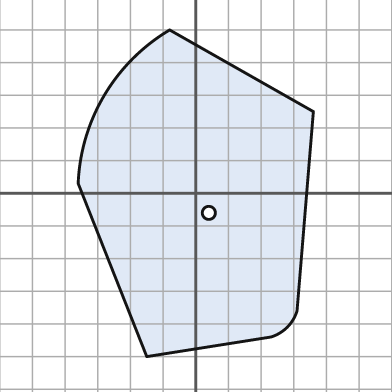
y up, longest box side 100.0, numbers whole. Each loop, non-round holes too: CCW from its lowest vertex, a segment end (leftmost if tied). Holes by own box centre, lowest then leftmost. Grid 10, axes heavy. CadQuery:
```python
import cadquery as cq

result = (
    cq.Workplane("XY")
    .moveTo(-15.0, -50.0)
    .lineTo(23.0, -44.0)
    .threePointArc((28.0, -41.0), (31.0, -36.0))
    .lineTo(36.0, 25.0)
    .lineTo(-8.0, 50.0)
    .threePointArc((-28.0, 30.0), (-36.0, 3.0))
    .close()
    .moveTo(4.0, -6.0)
    .circle(2.0)
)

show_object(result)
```